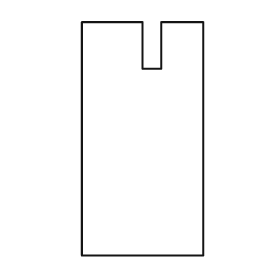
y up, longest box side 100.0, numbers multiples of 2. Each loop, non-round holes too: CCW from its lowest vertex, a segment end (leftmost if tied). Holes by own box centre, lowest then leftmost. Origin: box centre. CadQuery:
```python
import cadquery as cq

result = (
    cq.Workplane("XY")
    .moveTo(-26.0, -50.0)
    .lineTo(26.0, -50.0)
    .lineTo(26.0, 50.0)
    .lineTo(8.0, 50.0)
    .lineTo(8.0, 30.0)
    .lineTo(0.0, 30.0)
    .lineTo(0.0, 50.0)
    .lineTo(-26.0, 50.0)
    .close()
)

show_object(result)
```